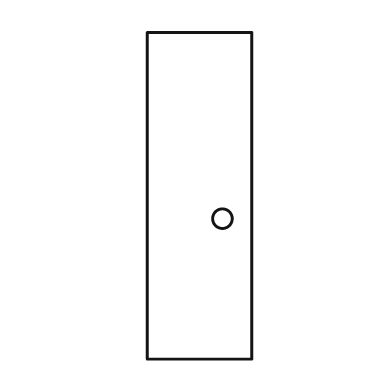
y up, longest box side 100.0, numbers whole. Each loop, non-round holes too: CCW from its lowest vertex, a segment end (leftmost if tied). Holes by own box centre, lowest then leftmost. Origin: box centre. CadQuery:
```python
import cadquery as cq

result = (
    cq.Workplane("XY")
    .moveTo(-16.0, -50.0)
    .lineTo(16.0, -50.0)
    .lineTo(16.0, 50.0)
    .lineTo(-16.0, 50.0)
    .close()
    .moveTo(7.0, -7.0)
    .circle(3.0)
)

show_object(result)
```